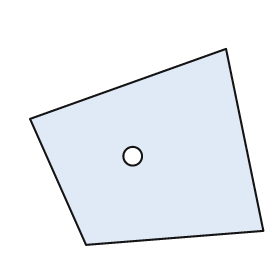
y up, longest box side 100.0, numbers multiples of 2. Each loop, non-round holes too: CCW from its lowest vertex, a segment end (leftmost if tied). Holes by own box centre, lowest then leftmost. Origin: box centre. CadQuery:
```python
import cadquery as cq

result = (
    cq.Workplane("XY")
    .moveTo(-26.0, -42.0)
    .lineTo(50.0, -36.0)
    .lineTo(34.0, 42.0)
    .lineTo(-50.0, 12.0)
    .close()
    .moveTo(-6.0, -4.0)
    .circle(4.0)
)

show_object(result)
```